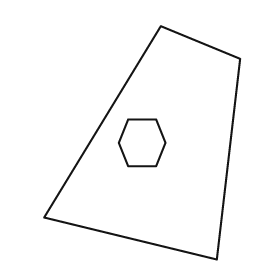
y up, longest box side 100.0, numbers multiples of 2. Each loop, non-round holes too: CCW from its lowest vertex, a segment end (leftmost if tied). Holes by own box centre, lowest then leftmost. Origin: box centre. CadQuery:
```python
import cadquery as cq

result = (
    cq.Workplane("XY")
    .moveTo(32.0, -50.0)
    .lineTo(42.0, 36.0)
    .lineTo(8.0, 50.0)
    .lineTo(-42.0, -32.0)
    .close()
    .moveTo(-6.0, -10.0)
    .lineTo(6.0, -10.0)
    .lineTo(10.0, 0.0)
    .lineTo(6.0, 10.0)
    .lineTo(-6.0, 10.0)
    .lineTo(-10.0, 0.0)
    .close()
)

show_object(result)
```